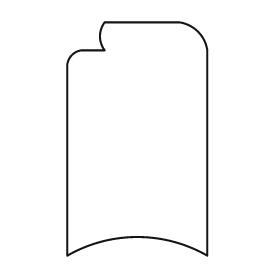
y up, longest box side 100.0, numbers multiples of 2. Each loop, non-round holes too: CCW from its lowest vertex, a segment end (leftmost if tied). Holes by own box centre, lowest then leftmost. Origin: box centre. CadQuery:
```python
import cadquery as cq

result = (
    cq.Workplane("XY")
    .moveTo(-30.0, -50.0)
    .threePointArc((0.0, -42.0), (30.0, -50.0))
    .lineTo(30.0, 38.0)
    .threePointArc((26.0, 46.0), (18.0, 50.0))
    .lineTo(-14.0, 50.0)
    .threePointArc((-16.0, 44.0), (-14.0, 38.0))
    .lineTo(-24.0, 38.0)
    .threePointArc((-28.0, 36.0), (-30.0, 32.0))
    .close()
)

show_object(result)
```